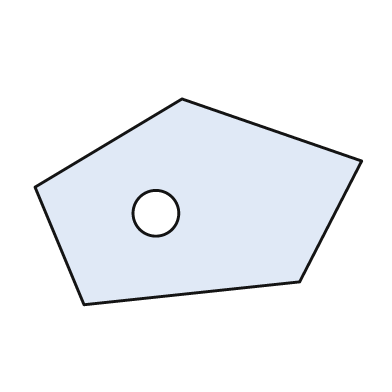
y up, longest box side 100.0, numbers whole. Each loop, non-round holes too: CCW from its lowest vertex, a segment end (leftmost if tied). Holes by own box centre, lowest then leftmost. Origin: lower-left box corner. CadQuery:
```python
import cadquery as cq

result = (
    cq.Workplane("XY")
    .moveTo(15.0, 0.0)
    .lineTo(81.0, 7.0)
    .lineTo(100.0, 44.0)
    .lineTo(45.0, 63.0)
    .lineTo(0.0, 36.0)
    .close()
    .moveTo(37.0, 28.0)
    .circle(7.0)
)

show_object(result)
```